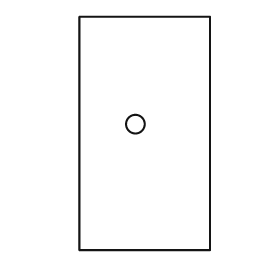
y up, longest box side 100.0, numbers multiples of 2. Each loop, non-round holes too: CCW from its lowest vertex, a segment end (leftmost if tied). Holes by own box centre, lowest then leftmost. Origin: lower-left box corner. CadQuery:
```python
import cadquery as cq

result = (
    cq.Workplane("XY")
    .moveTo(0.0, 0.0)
    .lineTo(56.0, 0.0)
    .lineTo(56.0, 100.0)
    .lineTo(0.0, 100.0)
    .close()
    .moveTo(24.0, 54.0)
    .circle(4.0)
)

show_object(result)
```